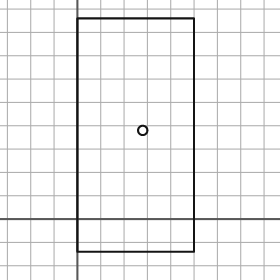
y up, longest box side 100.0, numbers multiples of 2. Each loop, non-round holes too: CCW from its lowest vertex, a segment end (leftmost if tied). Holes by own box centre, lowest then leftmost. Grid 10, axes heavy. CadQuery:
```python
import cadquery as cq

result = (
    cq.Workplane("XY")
    .moveTo(0.0, -14.0)
    .lineTo(50.0, -14.0)
    .lineTo(50.0, 86.0)
    .lineTo(0.0, 86.0)
    .close()
    .moveTo(28.0, 38.0)
    .circle(2.0)
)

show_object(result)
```